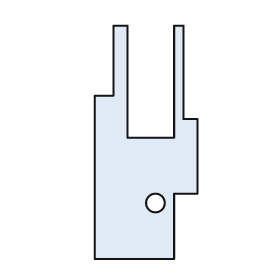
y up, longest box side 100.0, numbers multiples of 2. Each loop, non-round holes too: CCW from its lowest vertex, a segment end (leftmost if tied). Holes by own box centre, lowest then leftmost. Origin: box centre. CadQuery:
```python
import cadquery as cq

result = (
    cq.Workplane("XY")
    .moveTo(-22.0, -50.0)
    .lineTo(12.0, -50.0)
    .lineTo(12.0, -22.0)
    .lineTo(22.0, -22.0)
    .lineTo(22.0, 10.0)
    .lineTo(16.0, 10.0)
    .lineTo(16.0, 50.0)
    .lineTo(12.0, 50.0)
    .lineTo(12.0, 2.0)
    .lineTo(-8.0, 2.0)
    .lineTo(-8.0, 50.0)
    .lineTo(-14.0, 50.0)
    .lineTo(-14.0, 20.0)
    .lineTo(-22.0, 20.0)
    .close()
    .moveTo(4.0, -26.0)
    .circle(4.0)
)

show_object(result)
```